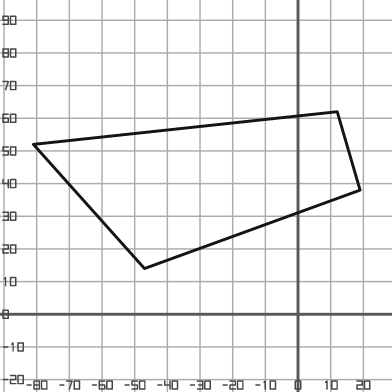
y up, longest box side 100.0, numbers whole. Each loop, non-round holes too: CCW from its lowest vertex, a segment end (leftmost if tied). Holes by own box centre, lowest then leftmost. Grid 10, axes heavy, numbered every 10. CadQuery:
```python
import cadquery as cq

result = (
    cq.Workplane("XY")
    .moveTo(-47.0, 14.0)
    .lineTo(19.0, 38.0)
    .lineTo(12.0, 62.0)
    .lineTo(-81.0, 52.0)
    .close()
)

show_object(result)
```